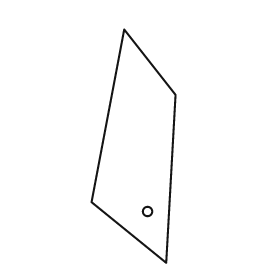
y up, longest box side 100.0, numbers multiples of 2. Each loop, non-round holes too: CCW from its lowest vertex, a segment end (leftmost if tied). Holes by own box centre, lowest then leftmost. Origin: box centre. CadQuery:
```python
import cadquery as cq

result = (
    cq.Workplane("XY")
    .moveTo(14.0, -50.0)
    .lineTo(18.0, 22.0)
    .lineTo(-4.0, 50.0)
    .lineTo(-18.0, -24.0)
    .close()
    .moveTo(6.0, -28.0)
    .circle(2.0)
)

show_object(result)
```